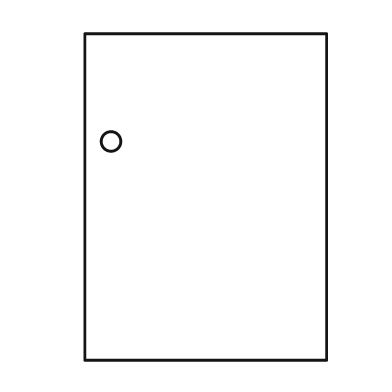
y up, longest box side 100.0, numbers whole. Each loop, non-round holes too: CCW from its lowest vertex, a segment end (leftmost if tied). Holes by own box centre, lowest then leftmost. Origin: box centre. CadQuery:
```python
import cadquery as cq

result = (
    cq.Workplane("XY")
    .moveTo(-37.0, -50.0)
    .lineTo(37.0, -50.0)
    .lineTo(37.0, 50.0)
    .lineTo(-37.0, 50.0)
    .close()
    .moveTo(-29.0, 17.0)
    .circle(3.0)
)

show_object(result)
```